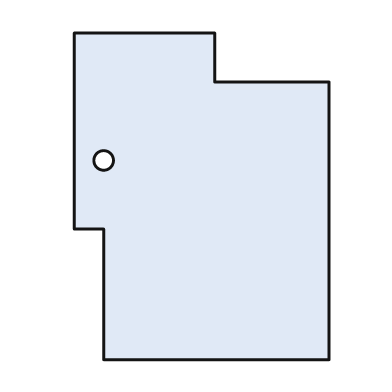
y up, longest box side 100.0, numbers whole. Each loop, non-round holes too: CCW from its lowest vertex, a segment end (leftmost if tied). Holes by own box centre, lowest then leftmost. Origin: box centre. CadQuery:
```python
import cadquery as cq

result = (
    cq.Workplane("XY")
    .moveTo(-30.0, -50.0)
    .lineTo(39.0, -50.0)
    .lineTo(39.0, 35.0)
    .lineTo(4.0, 35.0)
    .lineTo(4.0, 50.0)
    .lineTo(-39.0, 50.0)
    .lineTo(-39.0, -10.0)
    .lineTo(-30.0, -10.0)
    .close()
    .moveTo(-30.0, 11.0)
    .circle(3.0)
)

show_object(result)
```